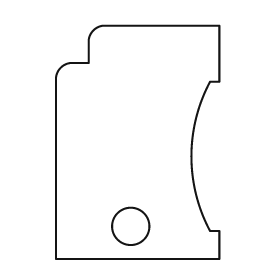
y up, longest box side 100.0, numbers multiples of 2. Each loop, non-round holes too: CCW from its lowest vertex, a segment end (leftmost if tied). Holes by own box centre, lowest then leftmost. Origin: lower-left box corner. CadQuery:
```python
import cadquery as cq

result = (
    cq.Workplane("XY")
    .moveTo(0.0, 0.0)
    .lineTo(70.0, 0.0)
    .lineTo(70.0, 12.0)
    .lineTo(66.0, 12.0)
    .threePointArc((58.0, 44.0), (66.0, 76.0))
    .lineTo(70.0, 76.0)
    .lineTo(70.0, 100.0)
    .lineTo(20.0, 100.0)
    .threePointArc((16.0, 98.0), (14.0, 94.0))
    .lineTo(14.0, 84.0)
    .lineTo(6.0, 84.0)
    .threePointArc((2.0, 82.0), (0.0, 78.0))
    .close()
    .moveTo(32.0, 14.0)
    .circle(8.0)
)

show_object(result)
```